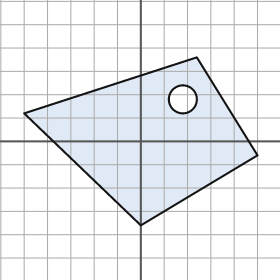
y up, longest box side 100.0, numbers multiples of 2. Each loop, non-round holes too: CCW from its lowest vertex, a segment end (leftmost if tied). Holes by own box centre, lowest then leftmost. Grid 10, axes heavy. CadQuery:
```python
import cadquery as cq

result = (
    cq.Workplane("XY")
    .moveTo(0.0, -36.0)
    .lineTo(50.0, -6.0)
    .lineTo(24.0, 36.0)
    .lineTo(-50.0, 12.0)
    .close()
    .moveTo(18.0, 18.0)
    .circle(6.0)
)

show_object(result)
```